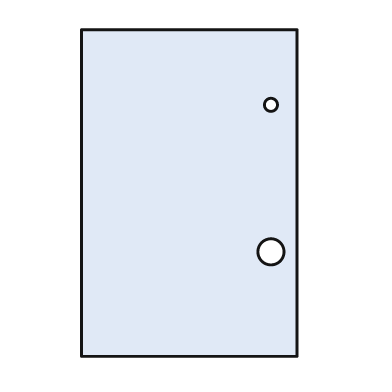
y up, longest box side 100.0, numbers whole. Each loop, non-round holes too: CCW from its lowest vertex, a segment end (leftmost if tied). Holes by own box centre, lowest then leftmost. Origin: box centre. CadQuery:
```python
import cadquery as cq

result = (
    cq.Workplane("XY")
    .moveTo(-33.0, -50.0)
    .lineTo(33.0, -50.0)
    .lineTo(33.0, 50.0)
    .lineTo(-33.0, 50.0)
    .close()
    .moveTo(25.0, -18.0)
    .circle(4.0)
    .moveTo(25.0, 27.0)
    .circle(2.0)
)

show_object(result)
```